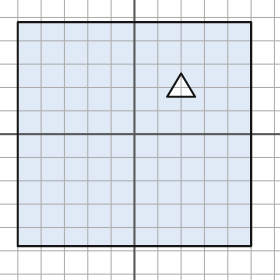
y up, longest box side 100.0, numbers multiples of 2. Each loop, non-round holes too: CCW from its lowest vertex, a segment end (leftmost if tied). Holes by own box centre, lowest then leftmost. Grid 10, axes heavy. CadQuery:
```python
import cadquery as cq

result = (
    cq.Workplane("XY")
    .moveTo(-50.0, -48.0)
    .lineTo(50.0, -48.0)
    .lineTo(50.0, 48.0)
    .lineTo(-50.0, 48.0)
    .close()
    .moveTo(14.0, 16.0)
    .lineTo(26.0, 16.0)
    .lineTo(20.0, 26.0)
    .close()
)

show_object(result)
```